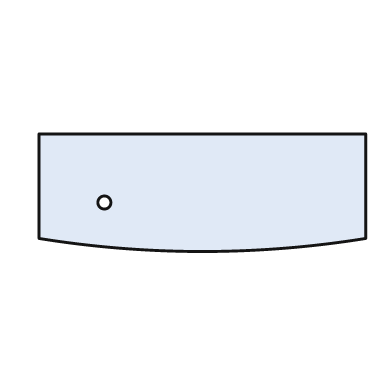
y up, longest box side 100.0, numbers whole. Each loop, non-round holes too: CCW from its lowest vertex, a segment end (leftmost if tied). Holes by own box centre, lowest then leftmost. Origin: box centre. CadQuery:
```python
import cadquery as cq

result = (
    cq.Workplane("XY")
    .moveTo(-50.0, -14.0)
    .threePointArc((0.0, -18.0), (50.0, -14.0))
    .lineTo(50.0, 18.0)
    .lineTo(-50.0, 18.0)
    .close()
    .moveTo(-30.0, -3.0)
    .circle(2.0)
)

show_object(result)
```